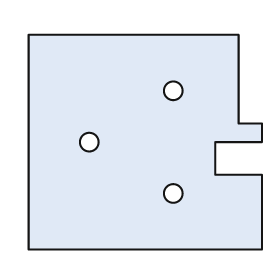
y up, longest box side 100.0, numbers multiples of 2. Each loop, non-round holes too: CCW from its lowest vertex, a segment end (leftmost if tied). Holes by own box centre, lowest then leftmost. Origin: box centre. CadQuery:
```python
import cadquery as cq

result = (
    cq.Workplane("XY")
    .moveTo(-50.0, -46.0)
    .lineTo(50.0, -46.0)
    .lineTo(50.0, -14.0)
    .lineTo(30.0, -14.0)
    .lineTo(30.0, 0.0)
    .lineTo(50.0, 0.0)
    .lineTo(50.0, 8.0)
    .lineTo(40.0, 8.0)
    .lineTo(40.0, 46.0)
    .lineTo(-50.0, 46.0)
    .close()
    .moveTo(12.0, -22.0)
    .circle(4.0)
    .moveTo(-24.0, 0.0)
    .circle(4.0)
    .moveTo(12.0, 22.0)
    .circle(4.0)
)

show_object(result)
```